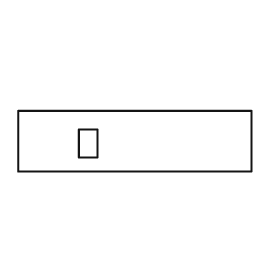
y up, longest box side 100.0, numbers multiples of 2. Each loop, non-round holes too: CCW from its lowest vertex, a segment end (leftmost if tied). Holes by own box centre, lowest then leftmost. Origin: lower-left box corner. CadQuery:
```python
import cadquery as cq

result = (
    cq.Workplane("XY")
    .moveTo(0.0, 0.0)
    .lineTo(100.0, 0.0)
    .lineTo(100.0, 26.0)
    .lineTo(0.0, 26.0)
    .close()
    .moveTo(26.0, 6.0)
    .lineTo(34.0, 6.0)
    .lineTo(34.0, 18.0)
    .lineTo(26.0, 18.0)
    .close()
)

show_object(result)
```